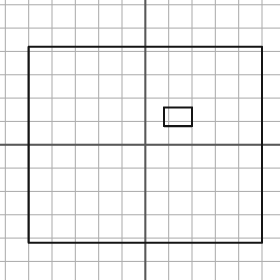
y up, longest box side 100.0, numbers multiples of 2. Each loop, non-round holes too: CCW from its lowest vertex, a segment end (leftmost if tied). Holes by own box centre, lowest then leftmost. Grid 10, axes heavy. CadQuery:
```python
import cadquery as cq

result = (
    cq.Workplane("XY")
    .moveTo(-50.0, -42.0)
    .lineTo(50.0, -42.0)
    .lineTo(50.0, 42.0)
    .lineTo(-50.0, 42.0)
    .close()
    .moveTo(8.0, 8.0)
    .lineTo(20.0, 8.0)
    .lineTo(20.0, 16.0)
    .lineTo(8.0, 16.0)
    .close()
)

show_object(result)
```